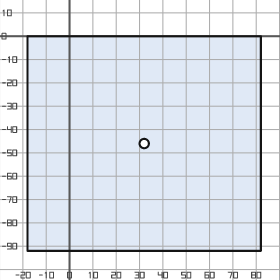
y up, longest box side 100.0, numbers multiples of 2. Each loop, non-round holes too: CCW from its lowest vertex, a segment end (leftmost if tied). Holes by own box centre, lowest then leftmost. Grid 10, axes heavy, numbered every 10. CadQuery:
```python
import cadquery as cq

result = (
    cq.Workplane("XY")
    .moveTo(-18.0, -92.0)
    .lineTo(82.0, -92.0)
    .lineTo(82.0, 0.0)
    .lineTo(-18.0, 0.0)
    .close()
    .moveTo(32.0, -46.0)
    .circle(2.0)
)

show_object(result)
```